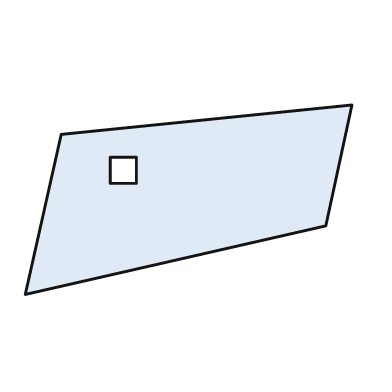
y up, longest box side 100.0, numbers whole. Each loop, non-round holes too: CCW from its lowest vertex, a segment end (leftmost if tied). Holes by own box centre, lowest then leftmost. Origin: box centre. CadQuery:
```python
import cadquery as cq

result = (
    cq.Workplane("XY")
    .moveTo(-50.0, -29.0)
    .lineTo(42.0, -8.0)
    .lineTo(50.0, 29.0)
    .lineTo(-39.0, 20.0)
    .close()
    .moveTo(-24.0, 5.0)
    .lineTo(-16.0, 5.0)
    .lineTo(-16.0, 13.0)
    .lineTo(-24.0, 13.0)
    .close()
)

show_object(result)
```